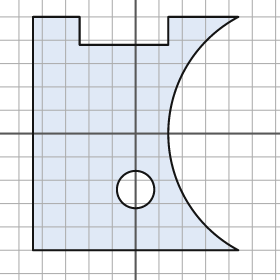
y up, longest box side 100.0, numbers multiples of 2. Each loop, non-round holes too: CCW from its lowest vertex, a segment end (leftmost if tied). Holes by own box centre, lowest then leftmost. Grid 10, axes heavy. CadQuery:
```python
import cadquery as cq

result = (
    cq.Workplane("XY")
    .moveTo(-44.0, -50.0)
    .lineTo(44.0, -50.0)
    .threePointArc((14.0, 0.0), (44.0, 50.0))
    .lineTo(14.0, 50.0)
    .lineTo(14.0, 38.0)
    .lineTo(-24.0, 38.0)
    .lineTo(-24.0, 50.0)
    .lineTo(-44.0, 50.0)
    .close()
    .moveTo(0.0, -24.0)
    .circle(8.0)
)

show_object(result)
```